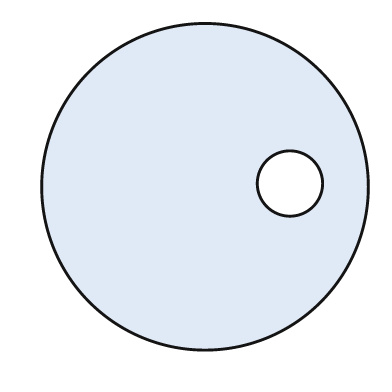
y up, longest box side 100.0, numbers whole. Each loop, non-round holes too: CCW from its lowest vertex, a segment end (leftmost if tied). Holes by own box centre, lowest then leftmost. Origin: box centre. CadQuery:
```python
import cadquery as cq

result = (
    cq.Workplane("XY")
    .moveTo(0.0, 0.0)
    .circle(50.0)
    .moveTo(26.0, 1.0)
    .circle(10.0)
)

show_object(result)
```